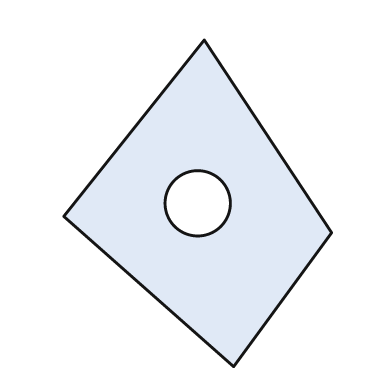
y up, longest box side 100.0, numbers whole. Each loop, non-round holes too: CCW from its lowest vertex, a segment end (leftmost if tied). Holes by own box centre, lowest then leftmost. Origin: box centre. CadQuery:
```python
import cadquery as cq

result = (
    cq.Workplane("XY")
    .moveTo(11.0, -50.0)
    .lineTo(41.0, -9.0)
    .lineTo(2.0, 50.0)
    .lineTo(-41.0, -4.0)
    .close()
    .moveTo(0.0, 0.0)
    .circle(10.0)
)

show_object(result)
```